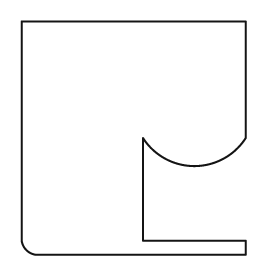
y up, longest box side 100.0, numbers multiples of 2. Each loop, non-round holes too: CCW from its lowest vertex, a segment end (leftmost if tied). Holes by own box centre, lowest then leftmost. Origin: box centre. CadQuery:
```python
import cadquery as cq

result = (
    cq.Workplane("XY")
    .moveTo(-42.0, -50.0)
    .lineTo(48.0, -50.0)
    .lineTo(48.0, -44.0)
    .lineTo(4.0, -44.0)
    .lineTo(4.0, 0.0)
    .threePointArc((26.0, -12.0), (48.0, 0.0))
    .lineTo(48.0, 50.0)
    .lineTo(-48.0, 50.0)
    .lineTo(-48.0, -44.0)
    .threePointArc((-46.0, -48.0), (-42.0, -50.0))
    .close()
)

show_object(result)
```